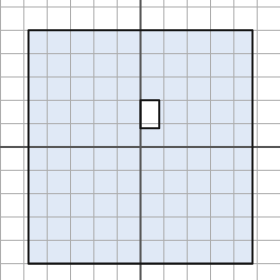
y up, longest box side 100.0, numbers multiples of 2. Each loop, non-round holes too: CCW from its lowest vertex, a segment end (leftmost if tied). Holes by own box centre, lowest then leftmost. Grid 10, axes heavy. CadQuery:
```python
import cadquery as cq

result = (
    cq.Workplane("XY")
    .moveTo(-48.0, -50.0)
    .lineTo(48.0, -50.0)
    .lineTo(48.0, 50.0)
    .lineTo(-48.0, 50.0)
    .close()
    .moveTo(0.0, 8.0)
    .lineTo(8.0, 8.0)
    .lineTo(8.0, 20.0)
    .lineTo(0.0, 20.0)
    .close()
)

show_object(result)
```